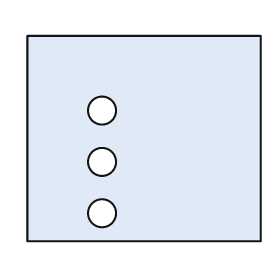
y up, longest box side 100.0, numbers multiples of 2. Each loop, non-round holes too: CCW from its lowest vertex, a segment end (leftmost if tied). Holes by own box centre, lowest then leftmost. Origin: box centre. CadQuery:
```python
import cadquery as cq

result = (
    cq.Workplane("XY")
    .moveTo(-50.0, -44.0)
    .lineTo(50.0, -44.0)
    .lineTo(50.0, 44.0)
    .lineTo(-50.0, 44.0)
    .close()
    .moveTo(-18.0, -32.0)
    .circle(6.0)
    .moveTo(-18.0, -10.0)
    .circle(6.0)
    .moveTo(-18.0, 12.0)
    .circle(6.0)
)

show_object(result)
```